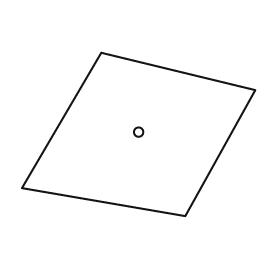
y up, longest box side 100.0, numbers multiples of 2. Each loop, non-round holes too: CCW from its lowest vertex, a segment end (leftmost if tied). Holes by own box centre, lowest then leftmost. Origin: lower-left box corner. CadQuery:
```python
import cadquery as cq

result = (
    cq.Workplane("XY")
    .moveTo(70.0, 0.0)
    .lineTo(100.0, 54.0)
    .lineTo(34.0, 70.0)
    .lineTo(0.0, 12.0)
    .close()
    .moveTo(50.0, 36.0)
    .circle(2.0)
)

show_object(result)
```